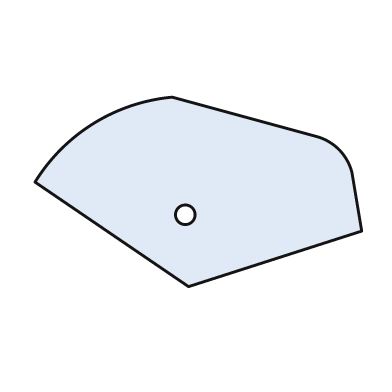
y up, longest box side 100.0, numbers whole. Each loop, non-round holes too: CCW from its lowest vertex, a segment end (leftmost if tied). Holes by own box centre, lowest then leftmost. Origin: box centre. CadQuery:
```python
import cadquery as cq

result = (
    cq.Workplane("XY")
    .moveTo(-3.0, -29.0)
    .lineTo(50.0, -12.0)
    .lineTo(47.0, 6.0)
    .threePointArc((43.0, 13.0), (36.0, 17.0))
    .lineTo(-8.0, 29.0)
    .threePointArc((-32.0, 21.0), (-50.0, 3.0))
    .close()
    .moveTo(-4.0, -7.0)
    .circle(3.0)
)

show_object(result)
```